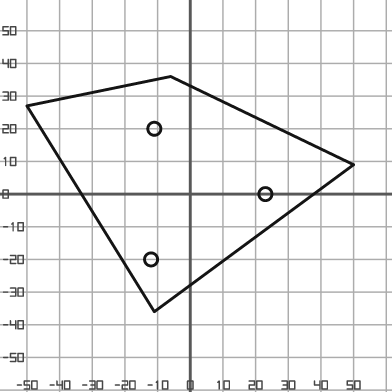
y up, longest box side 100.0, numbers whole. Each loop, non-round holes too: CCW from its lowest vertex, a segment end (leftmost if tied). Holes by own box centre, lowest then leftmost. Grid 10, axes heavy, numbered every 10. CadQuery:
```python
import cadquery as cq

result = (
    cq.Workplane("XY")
    .moveTo(-11.0, -36.0)
    .lineTo(50.0, 9.0)
    .lineTo(-6.0, 36.0)
    .lineTo(-50.0, 27.0)
    .close()
    .moveTo(-12.0, -20.0)
    .circle(2.0)
    .moveTo(23.0, 0.0)
    .circle(2.0)
    .moveTo(-11.0, 20.0)
    .circle(2.0)
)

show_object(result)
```